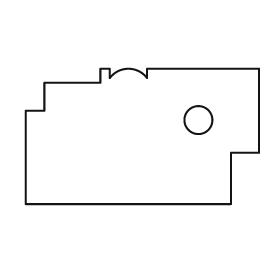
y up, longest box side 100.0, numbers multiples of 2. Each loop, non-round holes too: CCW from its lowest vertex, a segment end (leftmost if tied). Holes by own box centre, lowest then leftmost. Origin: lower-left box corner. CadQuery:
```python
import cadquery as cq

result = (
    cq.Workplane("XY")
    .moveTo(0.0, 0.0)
    .lineTo(88.0, 0.0)
    .lineTo(88.0, 22.0)
    .lineTo(100.0, 22.0)
    .lineTo(100.0, 58.0)
    .lineTo(52.0, 58.0)
    .lineTo(52.0, 54.0)
    .threePointArc((44.0, 58.0), (36.0, 54.0))
    .lineTo(36.0, 58.0)
    .lineTo(32.0, 58.0)
    .lineTo(32.0, 52.0)
    .lineTo(8.0, 52.0)
    .lineTo(8.0, 40.0)
    .lineTo(0.0, 40.0)
    .close()
    .moveTo(74.0, 36.0)
    .circle(6.0)
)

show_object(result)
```